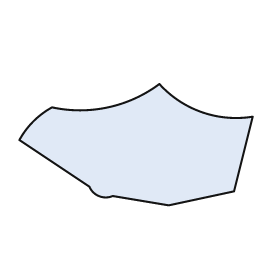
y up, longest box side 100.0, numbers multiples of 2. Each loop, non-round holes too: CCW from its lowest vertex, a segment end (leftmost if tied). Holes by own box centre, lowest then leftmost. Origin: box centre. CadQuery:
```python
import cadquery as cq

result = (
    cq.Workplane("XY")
    .moveTo(14.0, -26.0)
    .lineTo(42.0, -20.0)
    .lineTo(50.0, 12.0)
    .threePointArc((28.0, 14.0), (10.0, 26.0))
    .threePointArc((-12.0, 16.0), (-36.0, 16.0))
    .threePointArc((-44.0, 10.0), (-50.0, 2.0))
    .lineTo(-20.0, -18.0)
    .threePointArc((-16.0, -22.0), (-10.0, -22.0))
    .close()
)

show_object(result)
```